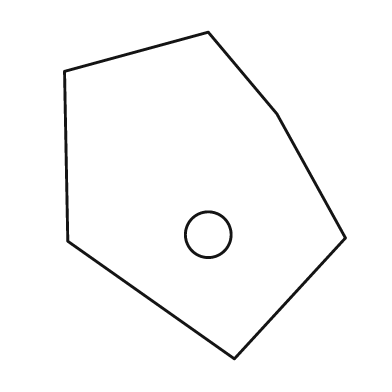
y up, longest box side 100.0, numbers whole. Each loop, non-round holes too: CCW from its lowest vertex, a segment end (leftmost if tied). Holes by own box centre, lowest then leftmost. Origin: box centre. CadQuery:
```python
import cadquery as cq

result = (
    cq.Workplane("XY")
    .moveTo(9.0, -50.0)
    .lineTo(43.0, -13.0)
    .lineTo(22.0, 25.0)
    .lineTo(1.0, 50.0)
    .lineTo(-43.0, 38.0)
    .lineTo(-42.0, -14.0)
    .close()
    .moveTo(1.0, -12.0)
    .circle(7.0)
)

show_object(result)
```